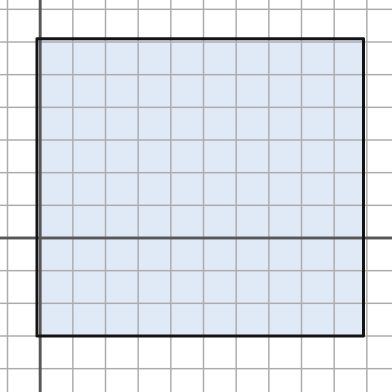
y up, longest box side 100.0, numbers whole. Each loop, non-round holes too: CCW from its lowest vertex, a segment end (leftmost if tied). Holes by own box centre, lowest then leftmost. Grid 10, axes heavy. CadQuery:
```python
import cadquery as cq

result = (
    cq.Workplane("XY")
    .moveTo(-1.0, -30.0)
    .lineTo(99.0, -30.0)
    .lineTo(99.0, 61.0)
    .lineTo(-1.0, 61.0)
    .close()
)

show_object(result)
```